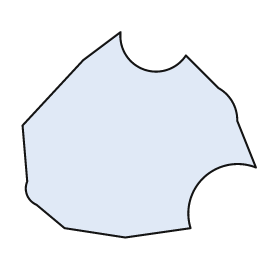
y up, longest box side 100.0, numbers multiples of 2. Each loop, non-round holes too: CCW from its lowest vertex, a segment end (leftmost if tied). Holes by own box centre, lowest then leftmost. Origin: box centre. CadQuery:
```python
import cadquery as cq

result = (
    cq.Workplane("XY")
    .moveTo(-6.0, -44.0)
    .lineTo(22.0, -40.0)
    .threePointArc((28.0, -18.0), (50.0, -14.0))
    .lineTo(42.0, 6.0)
    .threePointArc((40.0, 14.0), (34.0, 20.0))
    .lineTo(20.0, 34.0)
    .threePointArc((2.0, 28.0), (-8.0, 44.0))
    .lineTo(-24.0, 32.0)
    .lineTo(-50.0, 4.0)
    .lineTo(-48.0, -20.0)
    .threePointArc((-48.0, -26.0), (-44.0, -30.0))
    .lineTo(-32.0, -40.0)
    .close()
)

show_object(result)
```